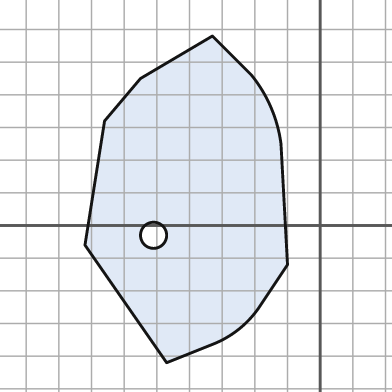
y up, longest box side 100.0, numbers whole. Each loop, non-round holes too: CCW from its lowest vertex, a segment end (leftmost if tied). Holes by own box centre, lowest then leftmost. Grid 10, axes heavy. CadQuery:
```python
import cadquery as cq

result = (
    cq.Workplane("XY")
    .moveTo(-47.0, -42.0)
    .lineTo(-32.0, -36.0)
    .threePointArc((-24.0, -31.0), (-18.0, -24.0))
    .lineTo(-10.0, -12.0)
    .lineTo(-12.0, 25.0)
    .threePointArc((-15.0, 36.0), (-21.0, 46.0))
    .lineTo(-33.0, 58.0)
    .lineTo(-55.0, 45.0)
    .lineTo(-66.0, 32.0)
    .lineTo(-72.0, -6.0)
    .close()
    .moveTo(-51.0, -3.0)
    .circle(4.0)
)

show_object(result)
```